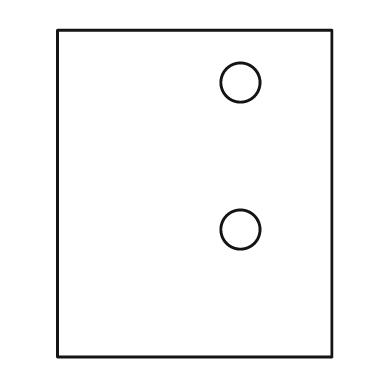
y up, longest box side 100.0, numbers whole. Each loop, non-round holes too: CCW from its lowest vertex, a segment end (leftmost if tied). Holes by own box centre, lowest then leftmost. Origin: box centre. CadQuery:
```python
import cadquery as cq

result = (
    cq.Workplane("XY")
    .moveTo(-42.0, -50.0)
    .lineTo(42.0, -50.0)
    .lineTo(42.0, 50.0)
    .lineTo(-42.0, 50.0)
    .close()
    .moveTo(14.0, -11.0)
    .circle(6.0)
    .moveTo(14.0, 34.0)
    .circle(6.0)
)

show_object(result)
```